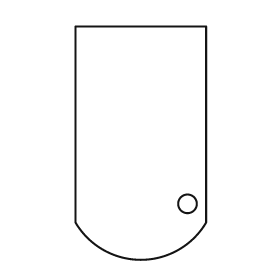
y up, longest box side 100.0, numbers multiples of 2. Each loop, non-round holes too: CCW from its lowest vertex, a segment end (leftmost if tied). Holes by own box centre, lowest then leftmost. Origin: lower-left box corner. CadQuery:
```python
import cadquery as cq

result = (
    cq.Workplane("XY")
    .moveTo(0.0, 16.0)
    .threePointArc((28.0, 0.0), (56.0, 16.0))
    .lineTo(56.0, 100.0)
    .lineTo(0.0, 100.0)
    .close()
    .moveTo(48.0, 24.0)
    .circle(4.0)
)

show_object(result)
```